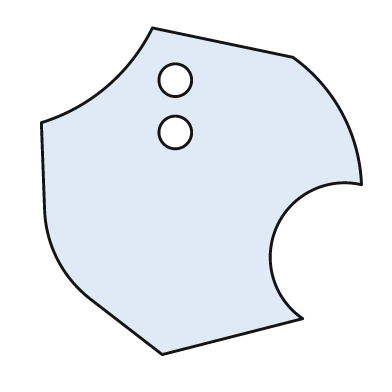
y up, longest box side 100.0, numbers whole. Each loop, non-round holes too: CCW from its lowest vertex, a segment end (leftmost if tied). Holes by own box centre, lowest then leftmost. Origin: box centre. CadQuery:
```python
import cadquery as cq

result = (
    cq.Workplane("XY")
    .moveTo(-12.0, -50.0)
    .lineTo(31.0, -39.0)
    .threePointArc((23.0, -11.0), (49.0, 2.0))
    .threePointArc((43.0, 24.0), (28.0, 41.0))
    .lineTo(-15.0, 50.0)
    .threePointArc((-29.0, 32.0), (-49.0, 21.0))
    .lineTo(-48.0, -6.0)
    .threePointArc((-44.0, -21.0), (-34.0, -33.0))
    .close()
    .moveTo(-8.0, 18.0)
    .circle(5.0)
    .moveTo(-8.0, 34.0)
    .circle(5.0)
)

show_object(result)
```